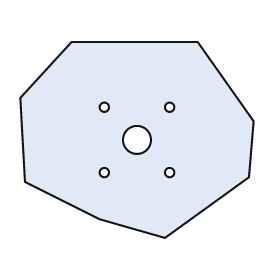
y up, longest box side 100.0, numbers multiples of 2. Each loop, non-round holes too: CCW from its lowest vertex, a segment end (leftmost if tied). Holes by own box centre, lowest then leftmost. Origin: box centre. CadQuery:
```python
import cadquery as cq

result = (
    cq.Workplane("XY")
    .moveTo(12.0, -42.0)
    .lineTo(48.0, -16.0)
    .lineTo(50.0, 8.0)
    .lineTo(26.0, 42.0)
    .lineTo(-28.0, 42.0)
    .lineTo(-50.0, 18.0)
    .lineTo(-48.0, -18.0)
    .lineTo(-16.0, -34.0)
    .close()
    .moveTo(-14.0, -14.0)
    .circle(2.0)
    .moveTo(14.0, -14.0)
    .circle(2.0)
    .moveTo(0.0, 0.0)
    .circle(6.0)
    .moveTo(-14.0, 14.0)
    .circle(2.0)
    .moveTo(14.0, 14.0)
    .circle(2.0)
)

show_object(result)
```